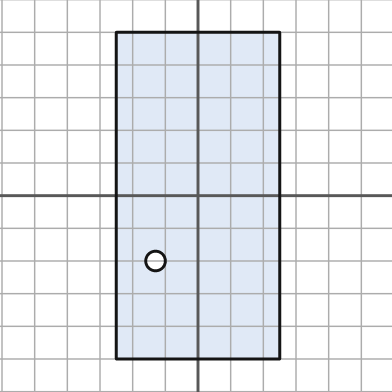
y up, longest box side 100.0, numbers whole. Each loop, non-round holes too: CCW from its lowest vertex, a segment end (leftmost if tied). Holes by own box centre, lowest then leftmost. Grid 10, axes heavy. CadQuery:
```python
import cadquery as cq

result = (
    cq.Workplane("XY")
    .moveTo(-25.0, -50.0)
    .lineTo(25.0, -50.0)
    .lineTo(25.0, 50.0)
    .lineTo(-25.0, 50.0)
    .close()
    .moveTo(-13.0, -20.0)
    .circle(3.0)
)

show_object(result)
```